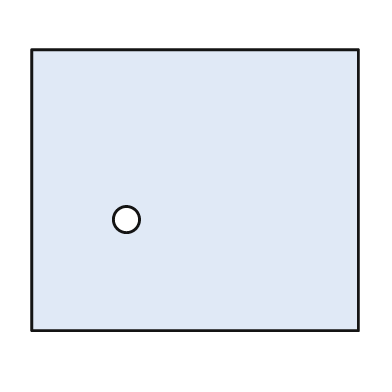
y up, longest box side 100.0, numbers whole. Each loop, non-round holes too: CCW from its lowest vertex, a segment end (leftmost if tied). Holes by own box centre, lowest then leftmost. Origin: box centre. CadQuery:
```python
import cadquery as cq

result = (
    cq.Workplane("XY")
    .moveTo(-50.0, -43.0)
    .lineTo(50.0, -43.0)
    .lineTo(50.0, 43.0)
    .lineTo(-50.0, 43.0)
    .close()
    .moveTo(-21.0, -9.0)
    .circle(4.0)
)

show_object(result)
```